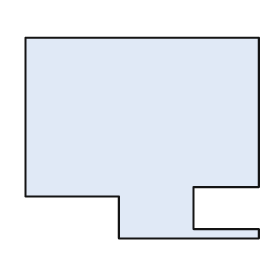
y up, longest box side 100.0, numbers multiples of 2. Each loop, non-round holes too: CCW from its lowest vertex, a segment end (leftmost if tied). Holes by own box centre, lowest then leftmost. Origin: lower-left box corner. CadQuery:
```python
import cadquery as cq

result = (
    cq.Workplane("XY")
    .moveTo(40.0, 0.0)
    .lineTo(100.0, 0.0)
    .lineTo(100.0, 4.0)
    .lineTo(72.0, 4.0)
    .lineTo(72.0, 22.0)
    .lineTo(100.0, 22.0)
    .lineTo(100.0, 86.0)
    .lineTo(0.0, 86.0)
    .lineTo(0.0, 18.0)
    .lineTo(40.0, 18.0)
    .close()
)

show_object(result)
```